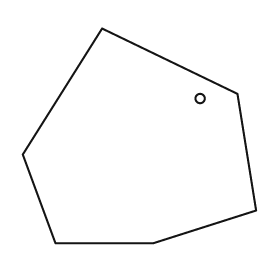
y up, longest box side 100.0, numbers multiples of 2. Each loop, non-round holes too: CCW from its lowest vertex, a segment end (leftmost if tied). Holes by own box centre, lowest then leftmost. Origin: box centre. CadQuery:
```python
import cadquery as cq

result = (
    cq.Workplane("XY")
    .moveTo(-36.0, -46.0)
    .lineTo(6.0, -46.0)
    .lineTo(50.0, -32.0)
    .lineTo(42.0, 18.0)
    .lineTo(-16.0, 46.0)
    .lineTo(-50.0, -8.0)
    .close()
    .moveTo(26.0, 16.0)
    .circle(2.0)
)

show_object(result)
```